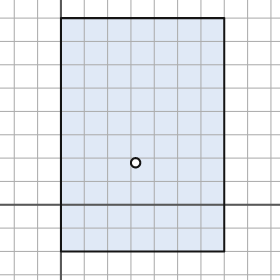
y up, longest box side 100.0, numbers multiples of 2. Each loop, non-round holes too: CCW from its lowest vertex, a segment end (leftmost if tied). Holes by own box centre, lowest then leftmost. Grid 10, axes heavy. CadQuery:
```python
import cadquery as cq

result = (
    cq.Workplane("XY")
    .moveTo(0.0, -20.0)
    .lineTo(70.0, -20.0)
    .lineTo(70.0, 80.0)
    .lineTo(0.0, 80.0)
    .close()
    .moveTo(32.0, 18.0)
    .circle(2.0)
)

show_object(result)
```